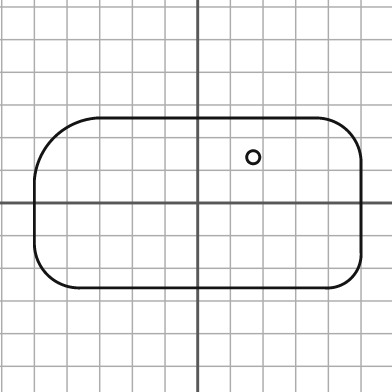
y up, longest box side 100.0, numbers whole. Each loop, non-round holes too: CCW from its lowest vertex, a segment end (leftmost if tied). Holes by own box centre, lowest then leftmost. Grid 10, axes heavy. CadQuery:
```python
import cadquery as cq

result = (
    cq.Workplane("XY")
    .moveTo(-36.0, -26.0)
    .lineTo(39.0, -26.0)
    .threePointArc((47.0, -23.0), (50.0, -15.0))
    .lineTo(50.0, 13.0)
    .threePointArc((46.0, 22.0), (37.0, 26.0))
    .lineTo(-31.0, 26.0)
    .threePointArc((-44.0, 20.0), (-50.0, 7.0))
    .lineTo(-50.0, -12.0)
    .threePointArc((-46.0, -22.0), (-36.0, -26.0))
    .close()
    .moveTo(17.0, 14.0)
    .circle(2.0)
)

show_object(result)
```